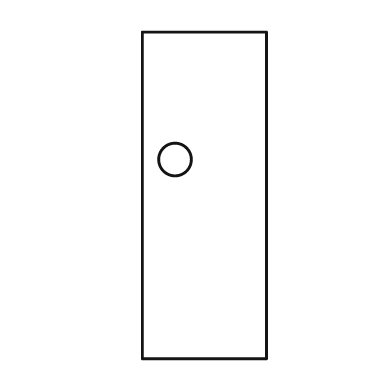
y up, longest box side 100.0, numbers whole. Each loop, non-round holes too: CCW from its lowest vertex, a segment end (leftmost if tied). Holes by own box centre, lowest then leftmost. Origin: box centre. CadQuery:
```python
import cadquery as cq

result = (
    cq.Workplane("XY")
    .moveTo(-19.0, -50.0)
    .lineTo(19.0, -50.0)
    .lineTo(19.0, 50.0)
    .lineTo(-19.0, 50.0)
    .close()
    .moveTo(-9.0, 11.0)
    .circle(5.0)
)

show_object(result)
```